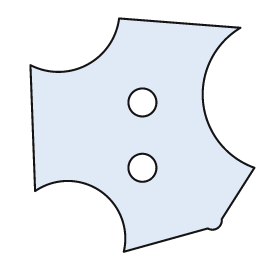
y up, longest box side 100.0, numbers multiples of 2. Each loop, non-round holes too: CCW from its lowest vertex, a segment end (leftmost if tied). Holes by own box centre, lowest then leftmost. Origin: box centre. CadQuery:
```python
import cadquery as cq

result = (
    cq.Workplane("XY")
    .moveTo(-8.0, -50.0)
    .lineTo(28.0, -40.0)
    .threePointArc((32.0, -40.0), (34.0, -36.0))
    .lineTo(48.0, -14.0)
    .threePointArc((26.0, 14.0), (42.0, 46.0))
    .lineTo(-10.0, 50.0)
    .threePointArc((-24.0, 30.0), (-48.0, 30.0))
    .lineTo(-46.0, -24.0)
    .threePointArc((-18.0, -24.0), (-8.0, -50.0))
    .close()
    .moveTo(0.0, -14.0)
    .circle(6.0)
    .moveTo(0.0, 14.0)
    .circle(6.0)
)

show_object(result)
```